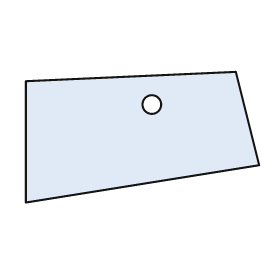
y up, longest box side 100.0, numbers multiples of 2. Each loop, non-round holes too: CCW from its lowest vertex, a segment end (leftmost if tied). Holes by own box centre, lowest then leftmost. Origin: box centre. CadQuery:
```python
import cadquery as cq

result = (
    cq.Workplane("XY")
    .moveTo(-50.0, -28.0)
    .lineTo(50.0, -12.0)
    .lineTo(40.0, 28.0)
    .lineTo(-50.0, 24.0)
    .close()
    .moveTo(4.0, 14.0)
    .circle(4.0)
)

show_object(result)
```